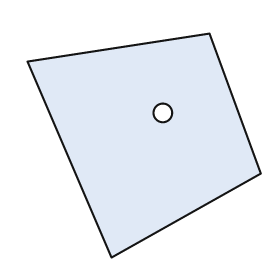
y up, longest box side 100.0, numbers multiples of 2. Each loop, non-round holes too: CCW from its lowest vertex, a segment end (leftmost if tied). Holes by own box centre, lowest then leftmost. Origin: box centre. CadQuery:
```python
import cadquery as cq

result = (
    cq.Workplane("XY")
    .moveTo(-14.0, -48.0)
    .lineTo(50.0, -12.0)
    .lineTo(28.0, 48.0)
    .lineTo(-50.0, 36.0)
    .close()
    .moveTo(8.0, 14.0)
    .circle(4.0)
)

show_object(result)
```